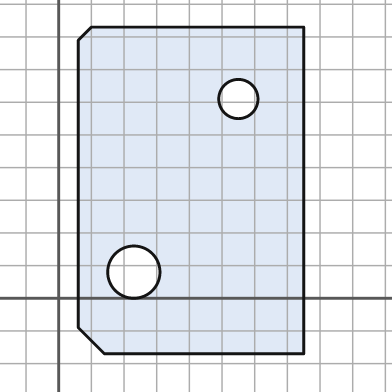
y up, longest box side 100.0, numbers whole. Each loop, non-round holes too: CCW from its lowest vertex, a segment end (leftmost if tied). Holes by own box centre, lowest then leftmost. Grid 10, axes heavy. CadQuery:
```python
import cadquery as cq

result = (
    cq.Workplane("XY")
    .moveTo(14.0, -17.0)
    .lineTo(75.0, -17.0)
    .lineTo(75.0, 83.0)
    .lineTo(10.0, 83.0)
    .lineTo(6.0, 79.0)
    .lineTo(6.0, -9.0)
    .close()
    .moveTo(23.0, 8.0)
    .circle(8.0)
    .moveTo(55.0, 61.0)
    .circle(6.0)
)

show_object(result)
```